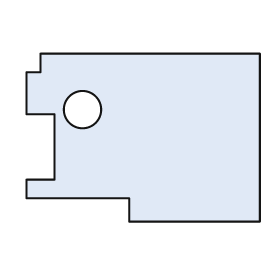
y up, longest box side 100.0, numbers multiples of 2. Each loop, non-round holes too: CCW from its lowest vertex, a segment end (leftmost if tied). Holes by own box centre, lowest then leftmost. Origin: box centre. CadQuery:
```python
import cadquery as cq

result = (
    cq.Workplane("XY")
    .moveTo(-6.0, -36.0)
    .lineTo(50.0, -36.0)
    .lineTo(50.0, 36.0)
    .lineTo(-44.0, 36.0)
    .lineTo(-44.0, 28.0)
    .lineTo(-50.0, 28.0)
    .lineTo(-50.0, 10.0)
    .lineTo(-38.0, 10.0)
    .lineTo(-38.0, -18.0)
    .lineTo(-50.0, -18.0)
    .lineTo(-50.0, -26.0)
    .lineTo(-6.0, -26.0)
    .close()
    .moveTo(-26.0, 12.0)
    .circle(8.0)
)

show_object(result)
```